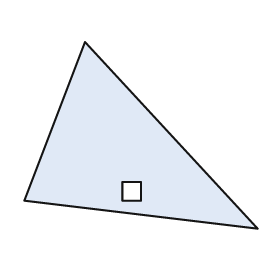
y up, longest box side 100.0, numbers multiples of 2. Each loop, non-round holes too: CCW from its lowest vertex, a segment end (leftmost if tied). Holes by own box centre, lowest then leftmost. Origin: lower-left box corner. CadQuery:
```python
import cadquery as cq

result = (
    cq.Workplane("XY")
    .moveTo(100.0, 0.0)
    .lineTo(26.0, 80.0)
    .lineTo(0.0, 12.0)
    .close()
    .moveTo(42.0, 12.0)
    .lineTo(50.0, 12.0)
    .lineTo(50.0, 20.0)
    .lineTo(42.0, 20.0)
    .close()
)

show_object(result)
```